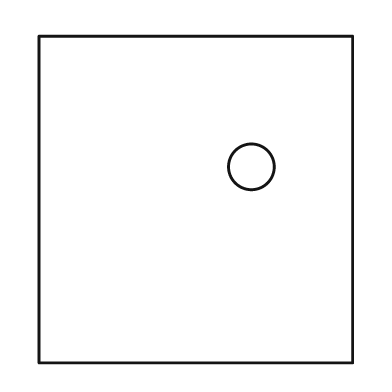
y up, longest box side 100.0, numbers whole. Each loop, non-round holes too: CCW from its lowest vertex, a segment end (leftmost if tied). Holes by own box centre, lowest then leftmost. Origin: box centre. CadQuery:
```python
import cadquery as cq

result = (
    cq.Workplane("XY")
    .moveTo(-48.0, -50.0)
    .lineTo(48.0, -50.0)
    .lineTo(48.0, 50.0)
    .lineTo(-48.0, 50.0)
    .close()
    .moveTo(17.0, 10.0)
    .circle(7.0)
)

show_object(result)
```